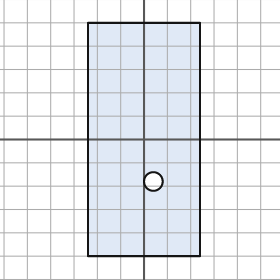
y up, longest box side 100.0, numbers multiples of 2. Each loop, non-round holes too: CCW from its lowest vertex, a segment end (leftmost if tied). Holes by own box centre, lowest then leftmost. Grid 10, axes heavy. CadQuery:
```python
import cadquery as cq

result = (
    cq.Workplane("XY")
    .moveTo(-24.0, -50.0)
    .lineTo(24.0, -50.0)
    .lineTo(24.0, 50.0)
    .lineTo(-24.0, 50.0)
    .close()
    .moveTo(4.0, -18.0)
    .circle(4.0)
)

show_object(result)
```